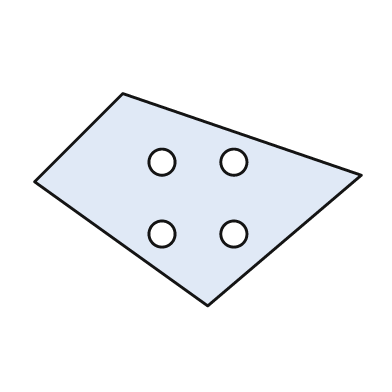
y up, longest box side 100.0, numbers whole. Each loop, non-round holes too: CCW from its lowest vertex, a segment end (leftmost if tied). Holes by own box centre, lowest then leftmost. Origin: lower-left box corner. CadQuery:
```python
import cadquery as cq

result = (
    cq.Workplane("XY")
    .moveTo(53.0, 0.0)
    .lineTo(100.0, 40.0)
    .lineTo(27.0, 65.0)
    .lineTo(0.0, 38.0)
    .close()
    .moveTo(39.0, 22.0)
    .circle(4.0)
    .moveTo(61.0, 22.0)
    .circle(4.0)
    .moveTo(39.0, 44.0)
    .circle(4.0)
    .moveTo(61.0, 44.0)
    .circle(4.0)
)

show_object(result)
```